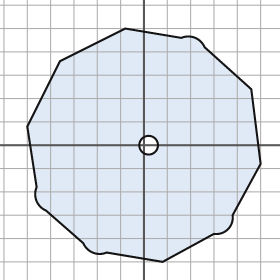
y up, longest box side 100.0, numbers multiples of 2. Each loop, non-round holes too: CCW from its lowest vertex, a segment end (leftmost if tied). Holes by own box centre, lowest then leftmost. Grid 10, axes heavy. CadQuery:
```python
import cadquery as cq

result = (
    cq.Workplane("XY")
    .moveTo(8.0, -50.0)
    .lineTo(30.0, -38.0)
    .threePointArc((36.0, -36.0), (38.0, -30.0))
    .lineTo(50.0, -8.0)
    .lineTo(46.0, 24.0)
    .lineTo(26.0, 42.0)
    .threePointArc((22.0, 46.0), (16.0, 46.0))
    .lineTo(-8.0, 50.0)
    .lineTo(-36.0, 36.0)
    .lineTo(-50.0, 8.0)
    .lineTo(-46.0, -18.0)
    .threePointArc((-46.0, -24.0), (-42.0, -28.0))
    .lineTo(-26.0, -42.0)
    .threePointArc((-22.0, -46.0), (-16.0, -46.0))
    .close()
    .moveTo(2.0, 0.0)
    .circle(4.0)
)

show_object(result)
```